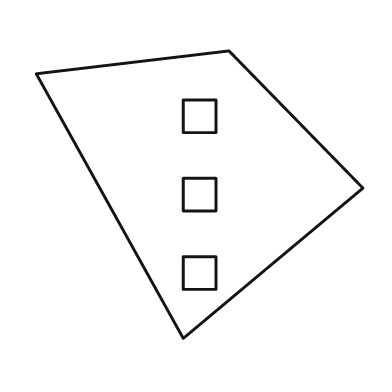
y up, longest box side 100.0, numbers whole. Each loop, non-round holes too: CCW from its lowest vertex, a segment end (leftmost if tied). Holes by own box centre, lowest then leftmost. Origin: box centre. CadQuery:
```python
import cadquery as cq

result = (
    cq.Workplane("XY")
    .moveTo(-5.0, -44.0)
    .lineTo(50.0, 2.0)
    .lineTo(9.0, 44.0)
    .lineTo(-50.0, 37.0)
    .close()
    .moveTo(-5.0, -29.0)
    .lineTo(5.0, -29.0)
    .lineTo(5.0, -19.0)
    .lineTo(-5.0, -19.0)
    .close()
    .moveTo(-5.0, -5.0)
    .lineTo(5.0, -5.0)
    .lineTo(5.0, 5.0)
    .lineTo(-5.0, 5.0)
    .close()
    .moveTo(-5.0, 19.0)
    .lineTo(5.0, 19.0)
    .lineTo(5.0, 29.0)
    .lineTo(-5.0, 29.0)
    .close()
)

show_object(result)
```